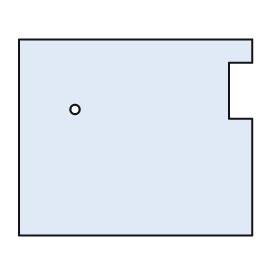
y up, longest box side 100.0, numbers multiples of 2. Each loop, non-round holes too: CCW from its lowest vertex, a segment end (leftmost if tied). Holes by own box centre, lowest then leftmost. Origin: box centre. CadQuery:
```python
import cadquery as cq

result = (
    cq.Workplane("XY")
    .moveTo(-50.0, -42.0)
    .lineTo(50.0, -42.0)
    .lineTo(50.0, 8.0)
    .lineTo(40.0, 8.0)
    .lineTo(40.0, 32.0)
    .lineTo(50.0, 32.0)
    .lineTo(50.0, 42.0)
    .lineTo(-50.0, 42.0)
    .close()
    .moveTo(-26.0, 12.0)
    .circle(2.0)
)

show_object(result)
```